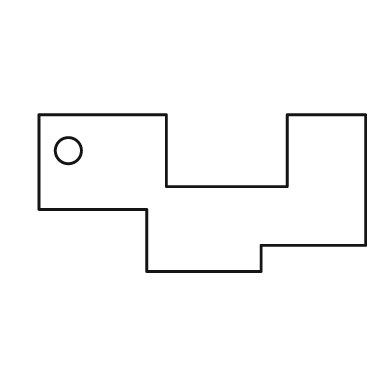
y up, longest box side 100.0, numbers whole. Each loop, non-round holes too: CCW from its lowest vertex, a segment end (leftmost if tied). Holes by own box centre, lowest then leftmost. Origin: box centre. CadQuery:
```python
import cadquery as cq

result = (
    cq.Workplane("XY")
    .moveTo(-17.0, -24.0)
    .lineTo(18.0, -24.0)
    .lineTo(18.0, -16.0)
    .lineTo(50.0, -16.0)
    .lineTo(50.0, 24.0)
    .lineTo(26.0, 24.0)
    .lineTo(26.0, 2.0)
    .lineTo(-11.0, 2.0)
    .lineTo(-11.0, 24.0)
    .lineTo(-50.0, 24.0)
    .lineTo(-50.0, -5.0)
    .lineTo(-17.0, -5.0)
    .close()
    .moveTo(-41.0, 13.0)
    .circle(4.0)
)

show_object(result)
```